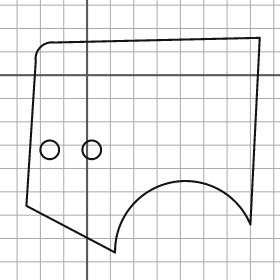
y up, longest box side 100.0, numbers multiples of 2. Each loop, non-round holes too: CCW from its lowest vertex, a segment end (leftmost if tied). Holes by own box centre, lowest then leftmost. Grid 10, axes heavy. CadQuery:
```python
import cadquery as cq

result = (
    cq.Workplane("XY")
    .moveTo(12.0, -76.0)
    .threePointArc((36.0, -46.0), (70.0, -64.0))
    .lineTo(74.0, 16.0)
    .lineTo(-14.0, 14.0)
    .threePointArc((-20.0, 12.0), (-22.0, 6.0))
    .lineTo(-26.0, -56.0)
    .close()
    .moveTo(-16.0, -32.0)
    .circle(4.0)
    .moveTo(2.0, -32.0)
    .circle(4.0)
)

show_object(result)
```